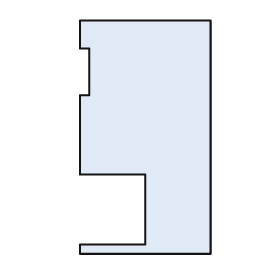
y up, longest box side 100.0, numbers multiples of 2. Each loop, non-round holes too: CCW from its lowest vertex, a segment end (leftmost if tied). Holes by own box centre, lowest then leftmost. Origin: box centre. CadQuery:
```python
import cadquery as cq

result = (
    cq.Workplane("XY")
    .moveTo(-28.0, -50.0)
    .lineTo(28.0, -50.0)
    .lineTo(28.0, 50.0)
    .lineTo(-28.0, 50.0)
    .lineTo(-28.0, 38.0)
    .lineTo(-24.0, 38.0)
    .lineTo(-24.0, 18.0)
    .lineTo(-28.0, 18.0)
    .lineTo(-28.0, -16.0)
    .lineTo(0.0, -16.0)
    .lineTo(0.0, -46.0)
    .lineTo(-28.0, -46.0)
    .close()
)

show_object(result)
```